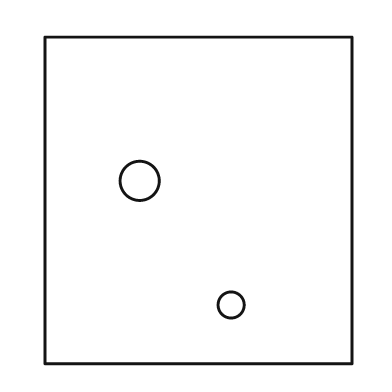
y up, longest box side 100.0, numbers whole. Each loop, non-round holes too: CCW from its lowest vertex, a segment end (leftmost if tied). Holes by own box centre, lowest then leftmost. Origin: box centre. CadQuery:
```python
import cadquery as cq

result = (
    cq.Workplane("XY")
    .moveTo(-47.0, -50.0)
    .lineTo(47.0, -50.0)
    .lineTo(47.0, 50.0)
    .lineTo(-47.0, 50.0)
    .close()
    .moveTo(10.0, -32.0)
    .circle(4.0)
    .moveTo(-18.0, 6.0)
    .circle(6.0)
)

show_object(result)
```